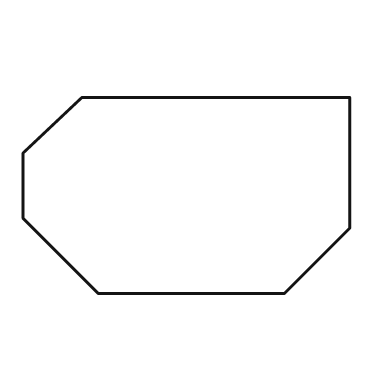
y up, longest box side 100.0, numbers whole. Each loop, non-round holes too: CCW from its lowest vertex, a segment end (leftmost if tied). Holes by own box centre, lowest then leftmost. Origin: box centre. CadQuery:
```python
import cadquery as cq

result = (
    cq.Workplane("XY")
    .moveTo(-27.0, -30.0)
    .lineTo(30.0, -30.0)
    .lineTo(50.0, -10.0)
    .lineTo(50.0, 30.0)
    .lineTo(-32.0, 30.0)
    .lineTo(-50.0, 13.0)
    .lineTo(-50.0, -7.0)
    .close()
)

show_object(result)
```